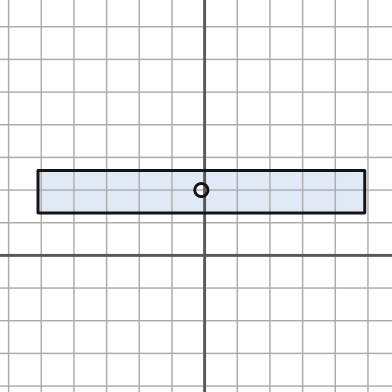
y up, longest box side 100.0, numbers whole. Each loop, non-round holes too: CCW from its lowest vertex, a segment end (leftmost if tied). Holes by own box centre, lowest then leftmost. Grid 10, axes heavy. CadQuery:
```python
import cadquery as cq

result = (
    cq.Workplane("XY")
    .moveTo(-51.0, 13.0)
    .lineTo(49.0, 13.0)
    .lineTo(49.0, 26.0)
    .lineTo(-51.0, 26.0)
    .close()
    .moveTo(-1.0, 20.0)
    .circle(2.0)
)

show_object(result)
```